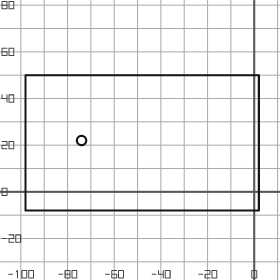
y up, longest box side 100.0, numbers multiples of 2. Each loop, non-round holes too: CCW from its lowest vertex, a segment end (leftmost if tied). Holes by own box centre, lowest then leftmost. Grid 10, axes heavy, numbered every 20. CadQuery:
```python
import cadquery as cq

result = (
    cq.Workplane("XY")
    .moveTo(-98.0, -8.0)
    .lineTo(2.0, -8.0)
    .lineTo(2.0, 50.0)
    .lineTo(-98.0, 50.0)
    .close()
    .moveTo(-74.0, 22.0)
    .circle(2.0)
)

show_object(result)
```